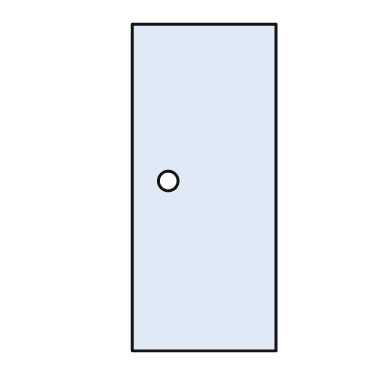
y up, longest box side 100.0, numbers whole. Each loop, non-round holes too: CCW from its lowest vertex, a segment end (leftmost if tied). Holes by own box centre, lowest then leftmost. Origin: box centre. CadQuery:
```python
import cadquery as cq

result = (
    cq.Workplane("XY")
    .moveTo(-22.0, -50.0)
    .lineTo(22.0, -50.0)
    .lineTo(22.0, 50.0)
    .lineTo(-22.0, 50.0)
    .close()
    .moveTo(-11.0, 2.0)
    .circle(3.0)
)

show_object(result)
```